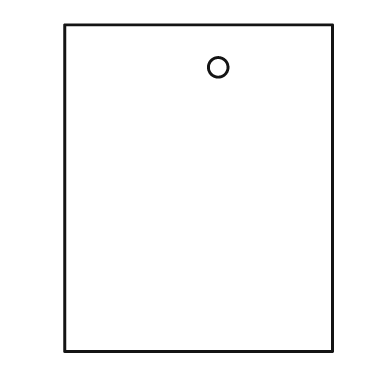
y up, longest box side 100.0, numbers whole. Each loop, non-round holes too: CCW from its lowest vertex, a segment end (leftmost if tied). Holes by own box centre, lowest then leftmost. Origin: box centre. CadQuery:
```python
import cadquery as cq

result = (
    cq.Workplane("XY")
    .moveTo(-41.0, -50.0)
    .lineTo(41.0, -50.0)
    .lineTo(41.0, 50.0)
    .lineTo(-41.0, 50.0)
    .close()
    .moveTo(6.0, 37.0)
    .circle(3.0)
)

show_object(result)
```